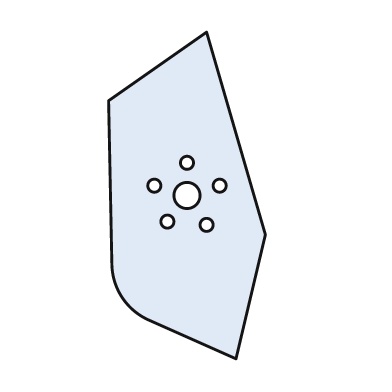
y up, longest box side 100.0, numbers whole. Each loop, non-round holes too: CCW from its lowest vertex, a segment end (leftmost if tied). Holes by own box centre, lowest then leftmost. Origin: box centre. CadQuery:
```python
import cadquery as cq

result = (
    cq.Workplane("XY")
    .moveTo(15.0, -50.0)
    .lineTo(24.0, -12.0)
    .lineTo(6.0, 50.0)
    .lineTo(-24.0, 29.0)
    .lineTo(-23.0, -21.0)
    .threePointArc((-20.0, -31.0), (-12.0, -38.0))
    .close()
    .moveTo(6.0, -9.0)
    .circle(2.0)
    .moveTo(-6.0, -8.0)
    .circle(2.0)
    .moveTo(0.0, 0.0)
    .circle(4.0)
    .moveTo(-10.0, 3.0)
    .circle(2.0)
    .moveTo(10.0, 3.0)
    .circle(2.0)
    .moveTo(0.0, 10.0)
    .circle(2.0)
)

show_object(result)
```